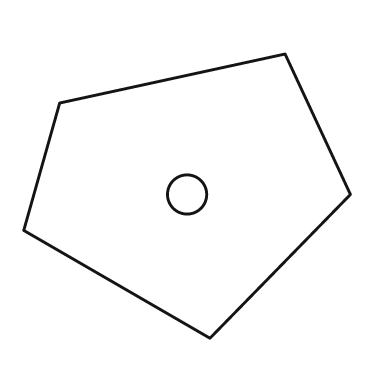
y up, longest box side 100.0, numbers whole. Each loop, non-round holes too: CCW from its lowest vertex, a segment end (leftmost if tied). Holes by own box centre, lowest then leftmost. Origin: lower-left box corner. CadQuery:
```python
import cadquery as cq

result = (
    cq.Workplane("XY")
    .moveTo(57.0, 0.0)
    .lineTo(100.0, 44.0)
    .lineTo(80.0, 87.0)
    .lineTo(11.0, 72.0)
    .lineTo(0.0, 33.0)
    .close()
    .moveTo(50.0, 44.0)
    .circle(6.0)
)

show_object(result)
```